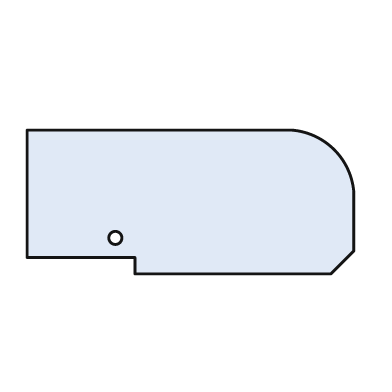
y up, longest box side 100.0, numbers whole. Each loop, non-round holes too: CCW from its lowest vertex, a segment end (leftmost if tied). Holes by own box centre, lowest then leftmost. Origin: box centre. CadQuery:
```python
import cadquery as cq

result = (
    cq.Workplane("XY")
    .moveTo(-17.0, -22.0)
    .lineTo(43.0, -22.0)
    .lineTo(50.0, -15.0)
    .lineTo(50.0, 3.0)
    .threePointArc((44.0, 16.0), (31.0, 22.0))
    .lineTo(-50.0, 22.0)
    .lineTo(-50.0, -17.0)
    .lineTo(-17.0, -17.0)
    .close()
    .moveTo(-23.0, -11.0)
    .circle(2.0)
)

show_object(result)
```